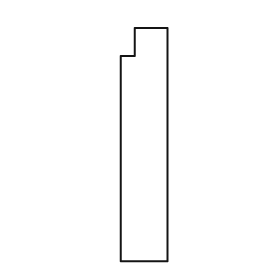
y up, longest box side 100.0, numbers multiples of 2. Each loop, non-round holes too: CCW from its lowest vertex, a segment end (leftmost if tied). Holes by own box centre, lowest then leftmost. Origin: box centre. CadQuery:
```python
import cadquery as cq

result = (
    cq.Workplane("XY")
    .moveTo(-10.0, -50.0)
    .lineTo(10.0, -50.0)
    .lineTo(10.0, 50.0)
    .lineTo(-4.0, 50.0)
    .lineTo(-4.0, 38.0)
    .lineTo(-10.0, 38.0)
    .close()
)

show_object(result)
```